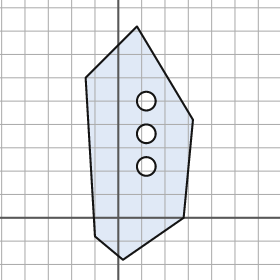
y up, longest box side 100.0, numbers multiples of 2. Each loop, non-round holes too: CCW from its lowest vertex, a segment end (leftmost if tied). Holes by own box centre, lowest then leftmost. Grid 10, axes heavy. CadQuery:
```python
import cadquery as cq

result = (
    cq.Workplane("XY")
    .moveTo(2.0, -18.0)
    .lineTo(28.0, 0.0)
    .lineTo(32.0, 42.0)
    .lineTo(8.0, 82.0)
    .lineTo(-14.0, 60.0)
    .lineTo(-10.0, -8.0)
    .close()
    .moveTo(12.0, 22.0)
    .circle(4.0)
    .moveTo(12.0, 36.0)
    .circle(4.0)
    .moveTo(12.0, 50.0)
    .circle(4.0)
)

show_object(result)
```